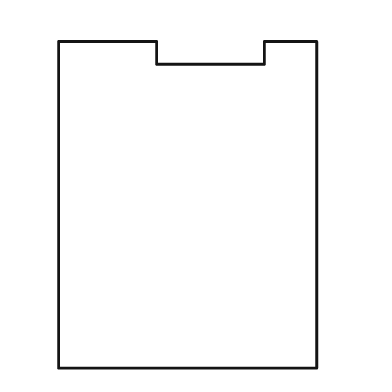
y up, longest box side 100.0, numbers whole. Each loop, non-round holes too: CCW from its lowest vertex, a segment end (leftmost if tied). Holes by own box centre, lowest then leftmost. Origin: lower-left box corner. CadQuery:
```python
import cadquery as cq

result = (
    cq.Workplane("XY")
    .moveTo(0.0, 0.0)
    .lineTo(79.0, 0.0)
    .lineTo(79.0, 100.0)
    .lineTo(63.0, 100.0)
    .lineTo(63.0, 93.0)
    .lineTo(30.0, 93.0)
    .lineTo(30.0, 100.0)
    .lineTo(0.0, 100.0)
    .close()
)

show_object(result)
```